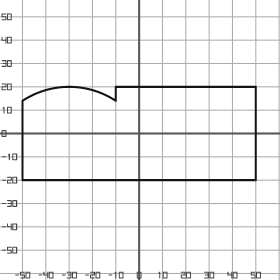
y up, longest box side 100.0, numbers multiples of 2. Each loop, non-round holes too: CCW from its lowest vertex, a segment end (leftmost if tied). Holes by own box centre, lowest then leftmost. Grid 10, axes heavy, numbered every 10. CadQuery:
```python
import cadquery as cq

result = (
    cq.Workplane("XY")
    .moveTo(-50.0, -20.0)
    .lineTo(50.0, -20.0)
    .lineTo(50.0, 20.0)
    .lineTo(-10.0, 20.0)
    .lineTo(-10.0, 14.0)
    .threePointArc((-30.0, 20.0), (-50.0, 14.0))
    .close()
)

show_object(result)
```